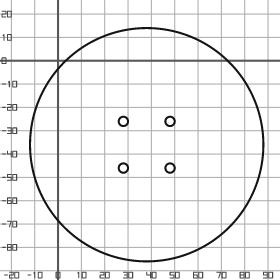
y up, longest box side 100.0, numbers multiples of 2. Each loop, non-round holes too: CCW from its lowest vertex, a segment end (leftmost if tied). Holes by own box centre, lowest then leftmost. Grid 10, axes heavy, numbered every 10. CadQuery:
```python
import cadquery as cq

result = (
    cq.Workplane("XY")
    .moveTo(38.0, -36.0)
    .circle(50.0)
    .moveTo(28.0, -46.0)
    .circle(2.0)
    .moveTo(48.0, -46.0)
    .circle(2.0)
    .moveTo(28.0, -26.0)
    .circle(2.0)
    .moveTo(48.0, -26.0)
    .circle(2.0)
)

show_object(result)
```